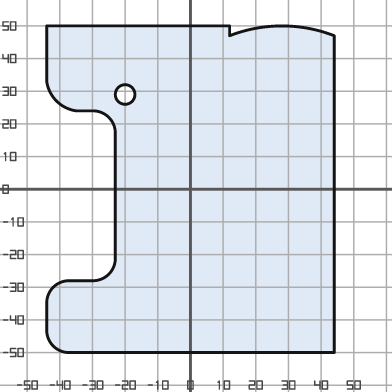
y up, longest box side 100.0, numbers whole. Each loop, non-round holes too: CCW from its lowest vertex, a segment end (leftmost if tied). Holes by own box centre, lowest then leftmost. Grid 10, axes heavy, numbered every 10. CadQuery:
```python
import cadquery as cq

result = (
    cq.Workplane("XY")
    .moveTo(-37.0, -50.0)
    .lineTo(44.0, -50.0)
    .lineTo(44.0, 47.0)
    .threePointArc((28.0, 50.0), (12.0, 47.0))
    .lineTo(12.0, 50.0)
    .lineTo(-44.0, 50.0)
    .lineTo(-44.0, 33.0)
    .threePointArc((-41.0, 27.0), (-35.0, 24.0))
    .lineTo(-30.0, 24.0)
    .threePointArc((-25.0, 22.0), (-23.0, 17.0))
    .lineTo(-23.0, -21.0)
    .threePointArc((-25.0, -26.0), (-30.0, -28.0))
    .lineTo(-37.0, -28.0)
    .threePointArc((-42.0, -30.0), (-44.0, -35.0))
    .lineTo(-44.0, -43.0)
    .threePointArc((-42.0, -48.0), (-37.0, -50.0))
    .close()
    .moveTo(-20.0, 29.0)
    .circle(3.0)
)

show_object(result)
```